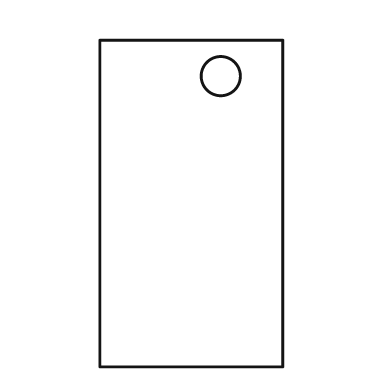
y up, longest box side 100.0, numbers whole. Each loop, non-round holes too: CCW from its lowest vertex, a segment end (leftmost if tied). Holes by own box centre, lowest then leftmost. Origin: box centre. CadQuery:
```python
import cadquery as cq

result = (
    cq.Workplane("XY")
    .moveTo(-28.0, -50.0)
    .lineTo(28.0, -50.0)
    .lineTo(28.0, 50.0)
    .lineTo(-28.0, 50.0)
    .close()
    .moveTo(9.0, 39.0)
    .circle(6.0)
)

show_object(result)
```